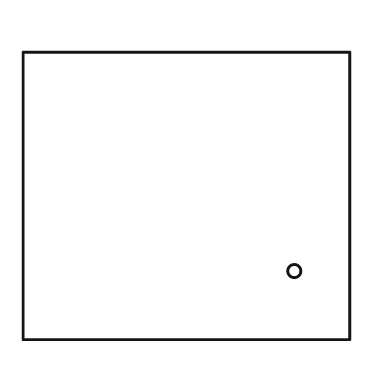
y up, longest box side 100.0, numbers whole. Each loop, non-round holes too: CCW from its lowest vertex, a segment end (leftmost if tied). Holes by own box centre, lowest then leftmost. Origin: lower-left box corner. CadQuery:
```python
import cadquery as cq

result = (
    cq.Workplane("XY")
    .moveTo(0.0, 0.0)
    .lineTo(100.0, 0.0)
    .lineTo(100.0, 88.0)
    .lineTo(0.0, 88.0)
    .close()
    .moveTo(83.0, 21.0)
    .circle(2.0)
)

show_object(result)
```